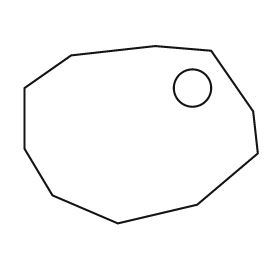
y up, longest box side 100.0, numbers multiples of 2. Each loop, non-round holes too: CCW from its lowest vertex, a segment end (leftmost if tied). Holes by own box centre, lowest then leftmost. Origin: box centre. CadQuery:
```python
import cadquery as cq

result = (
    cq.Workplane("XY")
    .moveTo(-10.0, -38.0)
    .lineTo(24.0, -30.0)
    .lineTo(50.0, -8.0)
    .lineTo(48.0, 10.0)
    .lineTo(30.0, 36.0)
    .lineTo(6.0, 38.0)
    .lineTo(-30.0, 34.0)
    .lineTo(-50.0, 20.0)
    .lineTo(-50.0, -6.0)
    .lineTo(-38.0, -26.0)
    .close()
    .moveTo(22.0, 20.0)
    .circle(8.0)
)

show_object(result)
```